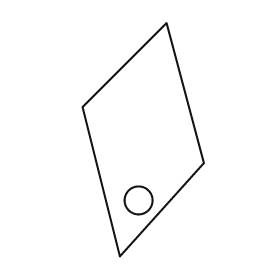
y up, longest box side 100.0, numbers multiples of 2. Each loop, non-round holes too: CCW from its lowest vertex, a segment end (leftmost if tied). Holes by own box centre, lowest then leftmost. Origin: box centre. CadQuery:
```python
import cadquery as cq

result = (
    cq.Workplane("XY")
    .moveTo(-10.0, -50.0)
    .lineTo(26.0, -10.0)
    .lineTo(10.0, 50.0)
    .lineTo(-26.0, 14.0)
    .close()
    .moveTo(-2.0, -26.0)
    .circle(6.0)
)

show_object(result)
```